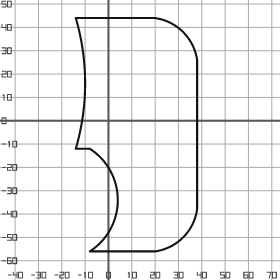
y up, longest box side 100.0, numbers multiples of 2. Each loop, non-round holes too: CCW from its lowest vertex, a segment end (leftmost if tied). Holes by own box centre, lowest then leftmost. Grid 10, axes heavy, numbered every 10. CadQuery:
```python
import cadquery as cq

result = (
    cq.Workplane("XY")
    .moveTo(-8.0, -56.0)
    .lineTo(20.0, -56.0)
    .threePointArc((32.0, -50.0), (38.0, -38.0))
    .lineTo(38.0, 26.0)
    .threePointArc((32.0, 38.0), (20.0, 44.0))
    .lineTo(-14.0, 44.0)
    .threePointArc((-10.0, 16.0), (-14.0, -12.0))
    .lineTo(-8.0, -12.0)
    .threePointArc((4.0, -34.0), (-8.0, -56.0))
    .close()
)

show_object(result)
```